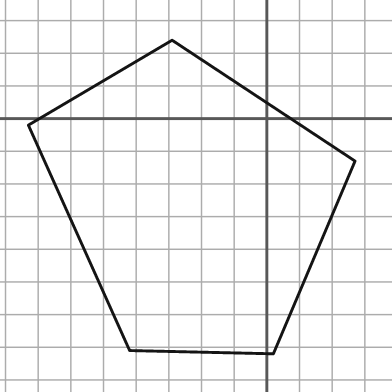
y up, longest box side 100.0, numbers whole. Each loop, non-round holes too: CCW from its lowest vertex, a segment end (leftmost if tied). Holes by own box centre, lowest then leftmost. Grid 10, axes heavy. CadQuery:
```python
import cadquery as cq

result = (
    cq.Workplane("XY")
    .moveTo(2.0, -72.0)
    .lineTo(27.0, -13.0)
    .lineTo(-29.0, 24.0)
    .lineTo(-73.0, -2.0)
    .lineTo(-42.0, -71.0)
    .close()
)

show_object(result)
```